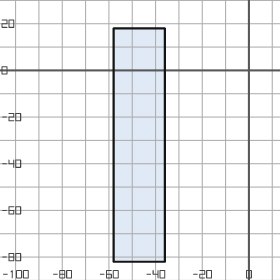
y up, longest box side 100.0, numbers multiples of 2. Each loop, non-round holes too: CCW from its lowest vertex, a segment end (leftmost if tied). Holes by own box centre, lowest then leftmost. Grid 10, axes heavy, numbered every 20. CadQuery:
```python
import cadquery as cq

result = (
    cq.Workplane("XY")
    .moveTo(-58.0, -82.0)
    .lineTo(-36.0, -82.0)
    .lineTo(-36.0, 18.0)
    .lineTo(-58.0, 18.0)
    .close()
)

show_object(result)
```